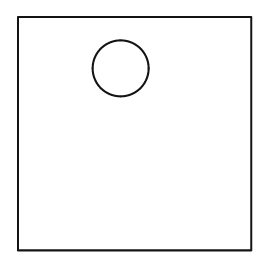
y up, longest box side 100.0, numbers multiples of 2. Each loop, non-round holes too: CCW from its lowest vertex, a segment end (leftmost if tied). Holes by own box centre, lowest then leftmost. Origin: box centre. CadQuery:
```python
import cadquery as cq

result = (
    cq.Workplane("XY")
    .moveTo(-50.0, -50.0)
    .lineTo(50.0, -50.0)
    .lineTo(50.0, 50.0)
    .lineTo(-50.0, 50.0)
    .close()
    .moveTo(-6.0, 28.0)
    .circle(12.0)
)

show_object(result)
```